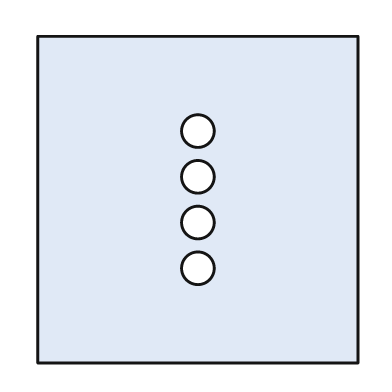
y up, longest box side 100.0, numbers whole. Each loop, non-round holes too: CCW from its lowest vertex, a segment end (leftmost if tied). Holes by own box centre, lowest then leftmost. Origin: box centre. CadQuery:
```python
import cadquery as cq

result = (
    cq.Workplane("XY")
    .moveTo(-49.0, -50.0)
    .lineTo(49.0, -50.0)
    .lineTo(49.0, 50.0)
    .lineTo(-49.0, 50.0)
    .close()
    .moveTo(0.0, -21.0)
    .circle(5.0)
    .moveTo(0.0, -7.0)
    .circle(5.0)
    .moveTo(0.0, 7.0)
    .circle(5.0)
    .moveTo(0.0, 21.0)
    .circle(5.0)
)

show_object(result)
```